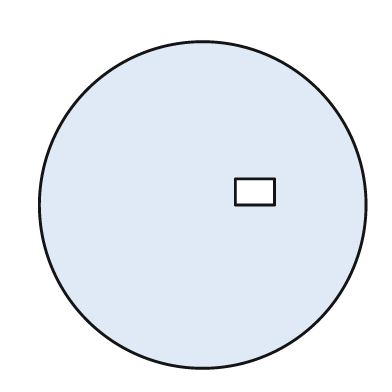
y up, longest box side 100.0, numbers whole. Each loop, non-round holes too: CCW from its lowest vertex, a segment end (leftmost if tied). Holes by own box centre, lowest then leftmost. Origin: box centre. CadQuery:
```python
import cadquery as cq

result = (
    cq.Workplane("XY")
    .moveTo(0.0, 0.0)
    .circle(50.0)
    .moveTo(10.0, 0.0)
    .lineTo(22.0, 0.0)
    .lineTo(22.0, 8.0)
    .lineTo(10.0, 8.0)
    .close()
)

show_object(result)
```